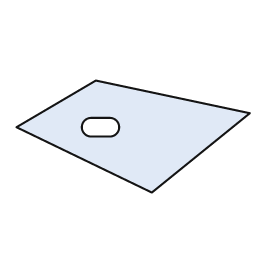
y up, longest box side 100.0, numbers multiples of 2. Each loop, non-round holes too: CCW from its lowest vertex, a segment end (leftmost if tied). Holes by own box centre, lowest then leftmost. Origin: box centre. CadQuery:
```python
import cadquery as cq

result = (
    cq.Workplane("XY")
    .moveTo(8.0, -24.0)
    .lineTo(50.0, 10.0)
    .lineTo(-16.0, 24.0)
    .lineTo(-50.0, 4.0)
    .close()
    .moveTo(-18.0, 0.0)
    .lineTo(-10.0, 0.0)
    .threePointArc((-6.0, 4.0), (-10.0, 8.0))
    .lineTo(-18.0, 8.0)
    .threePointArc((-22.0, 4.0), (-18.0, 0.0))
    .close()
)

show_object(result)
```